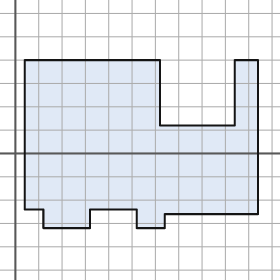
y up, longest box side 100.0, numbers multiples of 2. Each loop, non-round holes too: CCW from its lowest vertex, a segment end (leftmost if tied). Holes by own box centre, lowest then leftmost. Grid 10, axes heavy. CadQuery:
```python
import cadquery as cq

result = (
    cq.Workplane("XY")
    .moveTo(12.0, -32.0)
    .lineTo(32.0, -32.0)
    .lineTo(32.0, -24.0)
    .lineTo(52.0, -24.0)
    .lineTo(52.0, -32.0)
    .lineTo(64.0, -32.0)
    .lineTo(64.0, -26.0)
    .lineTo(104.0, -26.0)
    .lineTo(104.0, 40.0)
    .lineTo(94.0, 40.0)
    .lineTo(94.0, 12.0)
    .lineTo(62.0, 12.0)
    .lineTo(62.0, 40.0)
    .lineTo(4.0, 40.0)
    .lineTo(4.0, -24.0)
    .lineTo(12.0, -24.0)
    .close()
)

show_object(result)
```